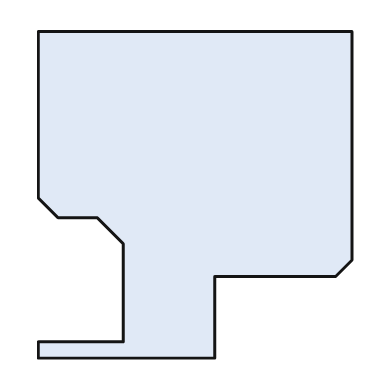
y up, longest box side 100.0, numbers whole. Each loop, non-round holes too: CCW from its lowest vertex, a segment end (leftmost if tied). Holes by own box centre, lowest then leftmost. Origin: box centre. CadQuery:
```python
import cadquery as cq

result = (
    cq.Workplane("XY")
    .moveTo(-48.0, -50.0)
    .lineTo(6.0, -50.0)
    .lineTo(6.0, -25.0)
    .lineTo(43.0, -25.0)
    .lineTo(48.0, -20.0)
    .lineTo(48.0, 50.0)
    .lineTo(-48.0, 50.0)
    .lineTo(-48.0, -1.0)
    .lineTo(-42.0, -7.0)
    .lineTo(-30.0, -7.0)
    .lineTo(-22.0, -15.0)
    .lineTo(-22.0, -45.0)
    .lineTo(-48.0, -45.0)
    .close()
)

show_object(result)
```